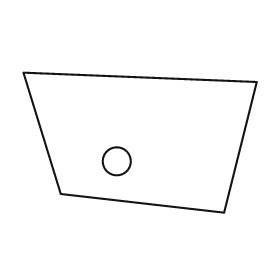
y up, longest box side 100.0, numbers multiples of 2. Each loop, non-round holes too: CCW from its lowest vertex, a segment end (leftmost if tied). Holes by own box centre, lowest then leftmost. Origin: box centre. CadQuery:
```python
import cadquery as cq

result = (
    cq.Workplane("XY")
    .moveTo(36.0, -30.0)
    .lineTo(50.0, 26.0)
    .lineTo(-50.0, 30.0)
    .lineTo(-34.0, -22.0)
    .close()
    .moveTo(-10.0, -8.0)
    .circle(6.0)
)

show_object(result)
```